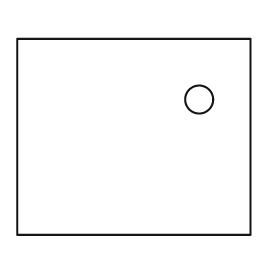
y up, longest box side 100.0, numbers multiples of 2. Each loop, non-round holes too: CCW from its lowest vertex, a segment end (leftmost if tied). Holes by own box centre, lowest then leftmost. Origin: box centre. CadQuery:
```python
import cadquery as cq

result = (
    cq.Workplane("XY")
    .moveTo(-50.0, -42.0)
    .lineTo(50.0, -42.0)
    .lineTo(50.0, 42.0)
    .lineTo(-50.0, 42.0)
    .close()
    .moveTo(28.0, 16.0)
    .circle(6.0)
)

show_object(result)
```